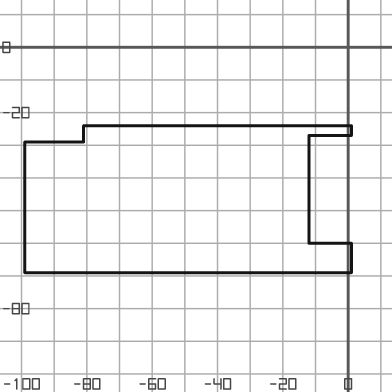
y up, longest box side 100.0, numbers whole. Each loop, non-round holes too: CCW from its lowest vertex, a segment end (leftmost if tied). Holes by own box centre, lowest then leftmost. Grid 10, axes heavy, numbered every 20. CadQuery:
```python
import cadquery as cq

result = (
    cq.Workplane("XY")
    .moveTo(-99.0, -69.0)
    .lineTo(1.0, -69.0)
    .lineTo(1.0, -60.0)
    .lineTo(-12.0, -60.0)
    .lineTo(-12.0, -27.0)
    .lineTo(1.0, -27.0)
    .lineTo(1.0, -24.0)
    .lineTo(-81.0, -24.0)
    .lineTo(-81.0, -29.0)
    .lineTo(-99.0, -29.0)
    .close()
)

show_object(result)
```